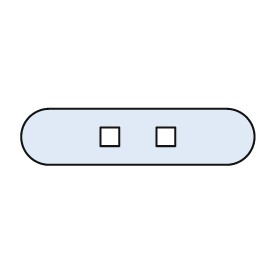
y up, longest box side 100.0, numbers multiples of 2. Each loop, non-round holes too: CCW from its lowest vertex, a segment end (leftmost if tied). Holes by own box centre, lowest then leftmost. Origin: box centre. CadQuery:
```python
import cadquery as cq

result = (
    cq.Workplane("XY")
    .moveTo(-38.0, -12.0)
    .lineTo(38.0, -12.0)
    .threePointArc((50.0, 0.0), (38.0, 12.0))
    .lineTo(-38.0, 12.0)
    .threePointArc((-50.0, 0.0), (-38.0, -12.0))
    .close()
    .moveTo(-16.0, -4.0)
    .lineTo(-8.0, -4.0)
    .lineTo(-8.0, 4.0)
    .lineTo(-16.0, 4.0)
    .close()
    .moveTo(8.0, -4.0)
    .lineTo(16.0, -4.0)
    .lineTo(16.0, 4.0)
    .lineTo(8.0, 4.0)
    .close()
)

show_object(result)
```